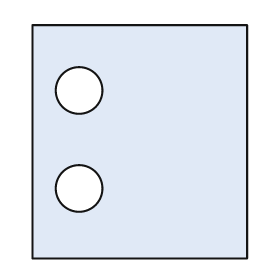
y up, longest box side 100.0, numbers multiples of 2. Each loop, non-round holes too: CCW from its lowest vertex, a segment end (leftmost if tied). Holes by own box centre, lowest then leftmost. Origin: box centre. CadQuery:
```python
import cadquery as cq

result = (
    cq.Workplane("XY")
    .moveTo(-46.0, -50.0)
    .lineTo(46.0, -50.0)
    .lineTo(46.0, 50.0)
    .lineTo(-46.0, 50.0)
    .close()
    .moveTo(-26.0, -20.0)
    .circle(10.0)
    .moveTo(-26.0, 22.0)
    .circle(10.0)
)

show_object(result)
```